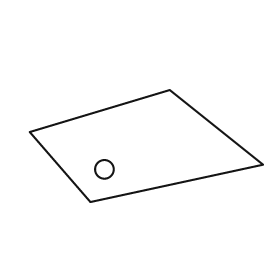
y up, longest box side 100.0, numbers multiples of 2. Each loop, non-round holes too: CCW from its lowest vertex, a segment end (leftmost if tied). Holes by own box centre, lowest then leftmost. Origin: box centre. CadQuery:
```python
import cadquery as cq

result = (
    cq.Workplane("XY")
    .moveTo(-24.0, -24.0)
    .lineTo(50.0, -8.0)
    .lineTo(10.0, 24.0)
    .lineTo(-50.0, 6.0)
    .close()
    .moveTo(-18.0, -10.0)
    .circle(4.0)
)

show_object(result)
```